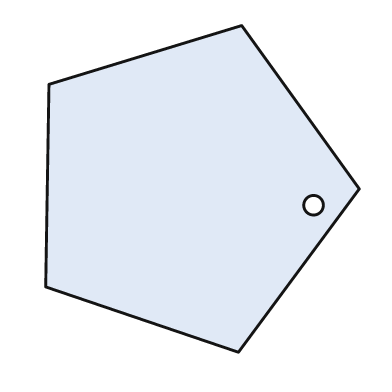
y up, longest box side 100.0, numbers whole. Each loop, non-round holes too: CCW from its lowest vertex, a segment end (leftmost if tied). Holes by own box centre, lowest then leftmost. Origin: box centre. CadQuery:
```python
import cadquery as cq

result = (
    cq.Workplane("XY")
    .moveTo(11.0, -50.0)
    .lineTo(48.0, 0.0)
    .lineTo(12.0, 50.0)
    .lineTo(-47.0, 32.0)
    .lineTo(-48.0, -30.0)
    .close()
    .moveTo(34.0, -5.0)
    .circle(3.0)
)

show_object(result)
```